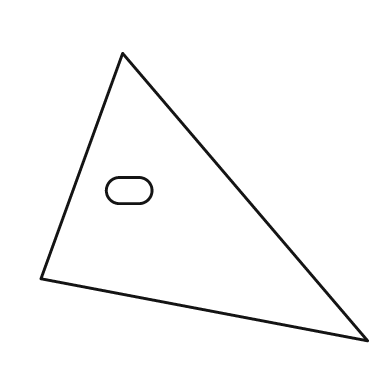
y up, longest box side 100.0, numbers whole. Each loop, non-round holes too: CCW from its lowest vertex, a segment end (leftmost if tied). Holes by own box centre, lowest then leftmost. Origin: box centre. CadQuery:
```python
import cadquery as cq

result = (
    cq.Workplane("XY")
    .moveTo(50.0, -44.0)
    .lineTo(-25.0, 44.0)
    .lineTo(-50.0, -25.0)
    .close()
    .moveTo(-26.0, -2.0)
    .lineTo(-20.0, -2.0)
    .threePointArc((-16.0, 2.0), (-20.0, 6.0))
    .lineTo(-26.0, 6.0)
    .threePointArc((-30.0, 2.0), (-26.0, -2.0))
    .close()
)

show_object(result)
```